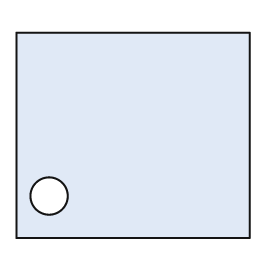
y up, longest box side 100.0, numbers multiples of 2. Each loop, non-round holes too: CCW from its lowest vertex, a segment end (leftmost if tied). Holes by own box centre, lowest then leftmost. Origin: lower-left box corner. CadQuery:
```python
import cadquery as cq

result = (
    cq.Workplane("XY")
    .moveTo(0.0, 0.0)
    .lineTo(100.0, 0.0)
    .lineTo(100.0, 88.0)
    .lineTo(0.0, 88.0)
    .close()
    .moveTo(14.0, 18.0)
    .circle(8.0)
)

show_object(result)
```